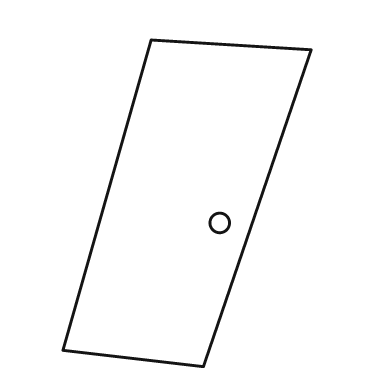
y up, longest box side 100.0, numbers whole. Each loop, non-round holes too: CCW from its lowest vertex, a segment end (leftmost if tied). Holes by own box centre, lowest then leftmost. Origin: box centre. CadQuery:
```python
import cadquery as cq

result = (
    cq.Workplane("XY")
    .moveTo(5.0, -50.0)
    .lineTo(38.0, 47.0)
    .lineTo(-11.0, 50.0)
    .lineTo(-38.0, -45.0)
    .close()
    .moveTo(10.0, -6.0)
    .circle(3.0)
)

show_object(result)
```